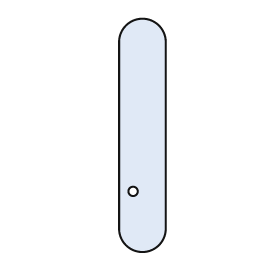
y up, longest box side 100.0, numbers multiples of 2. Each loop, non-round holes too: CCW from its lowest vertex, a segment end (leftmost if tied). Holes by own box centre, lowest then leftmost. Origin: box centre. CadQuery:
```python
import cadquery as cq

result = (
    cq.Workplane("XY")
    .moveTo(-10.0, -40.0)
    .threePointArc((0.0, -50.0), (10.0, -40.0))
    .lineTo(10.0, 40.0)
    .threePointArc((0.0, 50.0), (-10.0, 40.0))
    .close()
    .moveTo(-4.0, -24.0)
    .circle(2.0)
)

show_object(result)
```